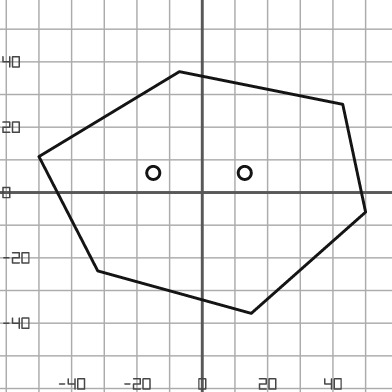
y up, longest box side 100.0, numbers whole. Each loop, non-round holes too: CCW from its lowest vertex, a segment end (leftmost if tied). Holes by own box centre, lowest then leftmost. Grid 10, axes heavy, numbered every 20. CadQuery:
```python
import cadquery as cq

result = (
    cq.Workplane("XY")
    .moveTo(15.0, -37.0)
    .lineTo(50.0, -6.0)
    .lineTo(43.0, 27.0)
    .lineTo(-7.0, 37.0)
    .lineTo(-50.0, 11.0)
    .lineTo(-32.0, -24.0)
    .close()
    .moveTo(-15.0, 6.0)
    .circle(2.0)
    .moveTo(13.0, 6.0)
    .circle(2.0)
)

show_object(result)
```